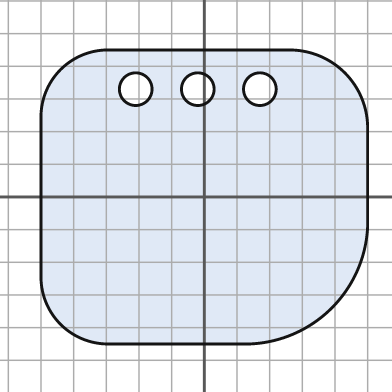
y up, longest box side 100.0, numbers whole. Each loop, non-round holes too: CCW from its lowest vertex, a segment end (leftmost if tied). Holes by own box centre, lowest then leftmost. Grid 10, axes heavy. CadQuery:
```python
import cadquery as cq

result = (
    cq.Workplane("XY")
    .moveTo(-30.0, -45.0)
    .lineTo(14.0, -45.0)
    .threePointArc((39.0, -34.0), (50.0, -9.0))
    .lineTo(50.0, 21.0)
    .threePointArc((43.0, 38.0), (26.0, 45.0))
    .lineTo(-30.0, 45.0)
    .threePointArc((-44.0, 39.0), (-50.0, 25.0))
    .lineTo(-50.0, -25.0)
    .threePointArc((-44.0, -39.0), (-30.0, -45.0))
    .close()
    .moveTo(-21.0, 33.0)
    .circle(5.0)
    .moveTo(-2.0, 33.0)
    .circle(5.0)
    .moveTo(17.0, 33.0)
    .circle(5.0)
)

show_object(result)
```